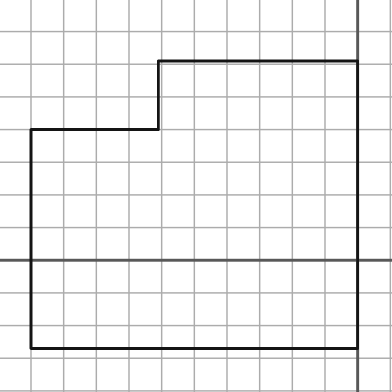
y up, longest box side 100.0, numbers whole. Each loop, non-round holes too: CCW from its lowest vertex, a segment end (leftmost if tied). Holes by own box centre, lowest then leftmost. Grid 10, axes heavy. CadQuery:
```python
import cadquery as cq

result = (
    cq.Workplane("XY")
    .moveTo(-100.0, -27.0)
    .lineTo(0.0, -27.0)
    .lineTo(0.0, 61.0)
    .lineTo(-61.0, 61.0)
    .lineTo(-61.0, 40.0)
    .lineTo(-100.0, 40.0)
    .close()
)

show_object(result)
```